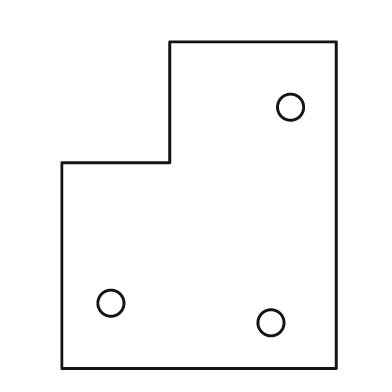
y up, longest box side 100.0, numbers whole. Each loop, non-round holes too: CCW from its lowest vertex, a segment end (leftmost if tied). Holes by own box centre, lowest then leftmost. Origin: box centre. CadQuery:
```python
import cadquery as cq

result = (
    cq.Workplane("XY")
    .moveTo(-42.0, -50.0)
    .lineTo(42.0, -50.0)
    .lineTo(42.0, 50.0)
    .lineTo(-9.0, 50.0)
    .lineTo(-9.0, 13.0)
    .lineTo(-42.0, 13.0)
    .close()
    .moveTo(22.0, -36.0)
    .circle(4.0)
    .moveTo(-27.0, -30.0)
    .circle(4.0)
    .moveTo(28.0, 30.0)
    .circle(4.0)
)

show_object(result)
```